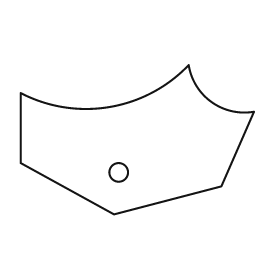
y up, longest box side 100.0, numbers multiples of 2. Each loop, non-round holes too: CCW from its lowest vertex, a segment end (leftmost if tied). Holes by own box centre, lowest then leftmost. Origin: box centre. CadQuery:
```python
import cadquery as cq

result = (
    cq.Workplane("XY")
    .moveTo(-10.0, -32.0)
    .lineTo(36.0, -20.0)
    .lineTo(50.0, 12.0)
    .threePointArc((32.0, 16.0), (22.0, 32.0))
    .threePointArc((-12.0, 14.0), (-50.0, 20.0))
    .lineTo(-50.0, -10.0)
    .close()
    .moveTo(-8.0, -14.0)
    .circle(4.0)
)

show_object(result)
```